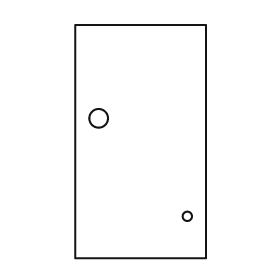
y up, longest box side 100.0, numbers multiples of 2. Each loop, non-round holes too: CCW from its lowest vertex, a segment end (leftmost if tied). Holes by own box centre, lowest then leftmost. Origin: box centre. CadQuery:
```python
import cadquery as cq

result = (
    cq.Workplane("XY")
    .moveTo(-28.0, -50.0)
    .lineTo(28.0, -50.0)
    .lineTo(28.0, 50.0)
    .lineTo(-28.0, 50.0)
    .close()
    .moveTo(20.0, -32.0)
    .circle(2.0)
    .moveTo(-18.0, 10.0)
    .circle(4.0)
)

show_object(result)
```